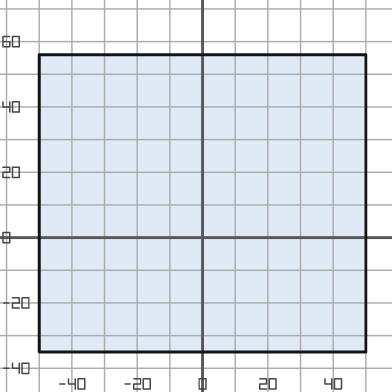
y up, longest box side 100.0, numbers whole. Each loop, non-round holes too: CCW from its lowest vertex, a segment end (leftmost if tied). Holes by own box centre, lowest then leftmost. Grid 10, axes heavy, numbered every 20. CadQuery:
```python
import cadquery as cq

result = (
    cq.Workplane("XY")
    .moveTo(-50.0, -35.0)
    .lineTo(50.0, -35.0)
    .lineTo(50.0, 56.0)
    .lineTo(-50.0, 56.0)
    .close()
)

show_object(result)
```